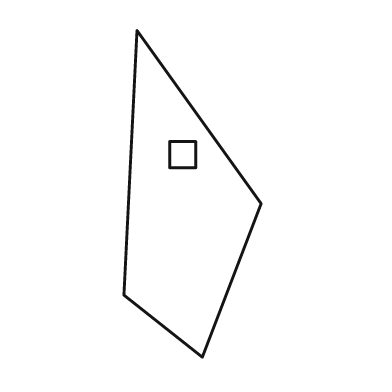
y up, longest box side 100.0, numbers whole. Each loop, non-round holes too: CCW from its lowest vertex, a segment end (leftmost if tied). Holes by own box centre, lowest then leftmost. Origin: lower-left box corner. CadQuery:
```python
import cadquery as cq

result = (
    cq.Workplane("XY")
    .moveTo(24.0, 0.0)
    .lineTo(42.0, 47.0)
    .lineTo(4.0, 100.0)
    .lineTo(0.0, 19.0)
    .close()
    .moveTo(14.0, 58.0)
    .lineTo(22.0, 58.0)
    .lineTo(22.0, 66.0)
    .lineTo(14.0, 66.0)
    .close()
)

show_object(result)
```